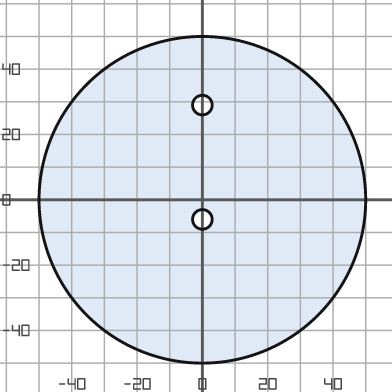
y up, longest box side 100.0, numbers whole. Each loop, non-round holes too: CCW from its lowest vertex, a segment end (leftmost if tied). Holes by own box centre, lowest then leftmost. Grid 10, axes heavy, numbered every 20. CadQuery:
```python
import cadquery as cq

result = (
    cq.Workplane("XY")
    .moveTo(0.0, 0.0)
    .circle(50.0)
    .moveTo(0.0, -6.0)
    .circle(3.0)
    .moveTo(0.0, 29.0)
    .circle(3.0)
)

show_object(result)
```